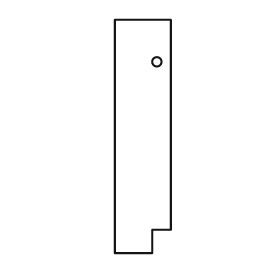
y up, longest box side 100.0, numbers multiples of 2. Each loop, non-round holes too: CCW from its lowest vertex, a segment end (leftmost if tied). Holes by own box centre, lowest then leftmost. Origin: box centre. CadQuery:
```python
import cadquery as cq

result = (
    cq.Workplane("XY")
    .moveTo(-12.0, -50.0)
    .lineTo(4.0, -50.0)
    .lineTo(4.0, -40.0)
    .lineTo(12.0, -40.0)
    .lineTo(12.0, 50.0)
    .lineTo(-12.0, 50.0)
    .close()
    .moveTo(6.0, 32.0)
    .circle(2.0)
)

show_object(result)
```